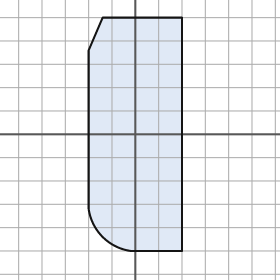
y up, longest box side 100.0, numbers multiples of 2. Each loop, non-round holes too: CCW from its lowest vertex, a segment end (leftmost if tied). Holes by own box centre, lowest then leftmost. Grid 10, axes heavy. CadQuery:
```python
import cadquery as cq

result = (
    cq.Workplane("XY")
    .moveTo(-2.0, -50.0)
    .lineTo(20.0, -50.0)
    .lineTo(20.0, 50.0)
    .lineTo(-14.0, 50.0)
    .lineTo(-20.0, 36.0)
    .lineTo(-20.0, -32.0)
    .threePointArc((-14.0, -44.0), (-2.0, -50.0))
    .close()
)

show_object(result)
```